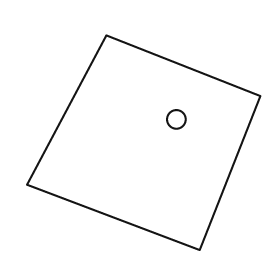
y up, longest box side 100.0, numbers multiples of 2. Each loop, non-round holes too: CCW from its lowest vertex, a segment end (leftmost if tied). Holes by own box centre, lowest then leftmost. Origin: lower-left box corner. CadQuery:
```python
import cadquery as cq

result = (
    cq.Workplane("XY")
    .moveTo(74.0, 0.0)
    .lineTo(100.0, 66.0)
    .lineTo(34.0, 92.0)
    .lineTo(0.0, 28.0)
    .close()
    .moveTo(64.0, 56.0)
    .circle(4.0)
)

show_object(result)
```